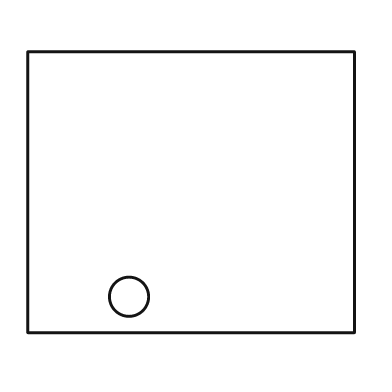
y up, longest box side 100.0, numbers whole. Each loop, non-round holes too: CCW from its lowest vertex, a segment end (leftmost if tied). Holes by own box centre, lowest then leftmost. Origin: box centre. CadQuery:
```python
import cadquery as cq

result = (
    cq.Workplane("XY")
    .moveTo(-50.0, -43.0)
    .lineTo(50.0, -43.0)
    .lineTo(50.0, 43.0)
    .lineTo(-50.0, 43.0)
    .close()
    .moveTo(-19.0, -32.0)
    .circle(6.0)
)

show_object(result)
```